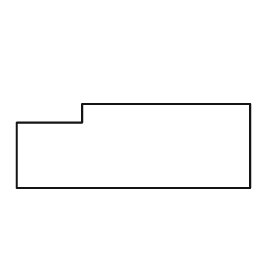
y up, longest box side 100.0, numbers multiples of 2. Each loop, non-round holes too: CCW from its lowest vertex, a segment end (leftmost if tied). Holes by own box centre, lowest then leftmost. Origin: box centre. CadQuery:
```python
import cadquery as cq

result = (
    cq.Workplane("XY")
    .moveTo(-50.0, -18.0)
    .lineTo(50.0, -18.0)
    .lineTo(50.0, 18.0)
    .lineTo(-22.0, 18.0)
    .lineTo(-22.0, 10.0)
    .lineTo(-50.0, 10.0)
    .close()
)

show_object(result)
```